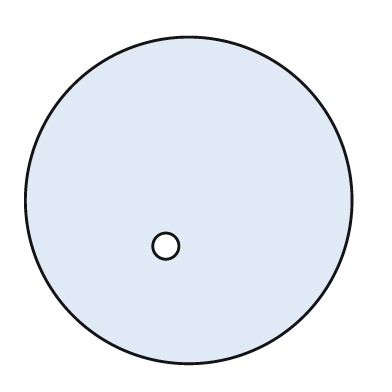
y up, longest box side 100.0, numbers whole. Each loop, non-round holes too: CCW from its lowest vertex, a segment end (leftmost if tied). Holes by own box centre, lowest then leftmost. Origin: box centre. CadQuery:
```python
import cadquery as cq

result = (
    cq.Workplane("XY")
    .moveTo(0.0, 0.0)
    .circle(50.0)
    .moveTo(-7.0, -14.0)
    .circle(4.0)
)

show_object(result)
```